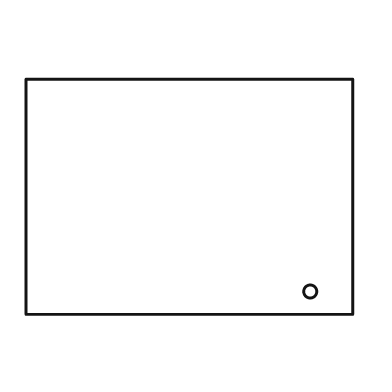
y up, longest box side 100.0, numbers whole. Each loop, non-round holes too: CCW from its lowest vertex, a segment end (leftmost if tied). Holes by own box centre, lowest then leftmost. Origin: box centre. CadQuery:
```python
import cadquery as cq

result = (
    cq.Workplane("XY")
    .moveTo(-50.0, -36.0)
    .lineTo(50.0, -36.0)
    .lineTo(50.0, 36.0)
    .lineTo(-50.0, 36.0)
    .close()
    .moveTo(37.0, -29.0)
    .circle(2.0)
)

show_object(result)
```